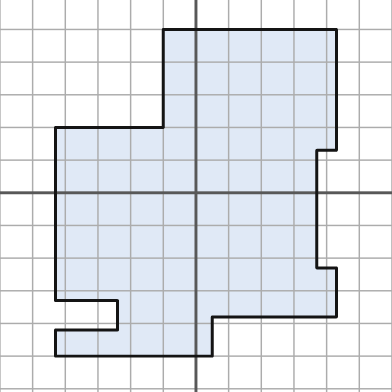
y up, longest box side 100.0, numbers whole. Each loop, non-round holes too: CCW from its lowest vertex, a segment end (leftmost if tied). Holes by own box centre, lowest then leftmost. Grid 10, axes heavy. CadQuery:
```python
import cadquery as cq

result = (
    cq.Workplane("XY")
    .moveTo(-43.0, -50.0)
    .lineTo(5.0, -50.0)
    .lineTo(5.0, -38.0)
    .lineTo(43.0, -38.0)
    .lineTo(43.0, -23.0)
    .lineTo(37.0, -23.0)
    .lineTo(37.0, 13.0)
    .lineTo(43.0, 13.0)
    .lineTo(43.0, 50.0)
    .lineTo(-10.0, 50.0)
    .lineTo(-10.0, 20.0)
    .lineTo(-43.0, 20.0)
    .lineTo(-43.0, -33.0)
    .lineTo(-24.0, -33.0)
    .lineTo(-24.0, -42.0)
    .lineTo(-43.0, -42.0)
    .close()
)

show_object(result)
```